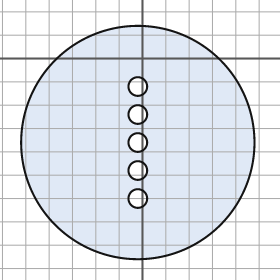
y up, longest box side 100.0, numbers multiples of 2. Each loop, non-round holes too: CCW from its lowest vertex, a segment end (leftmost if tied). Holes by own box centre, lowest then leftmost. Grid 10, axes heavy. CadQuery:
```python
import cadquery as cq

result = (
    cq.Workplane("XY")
    .moveTo(-2.0, -36.0)
    .circle(50.0)
    .moveTo(-2.0, -60.0)
    .circle(4.0)
    .moveTo(-2.0, -48.0)
    .circle(4.0)
    .moveTo(-2.0, -36.0)
    .circle(4.0)
    .moveTo(-2.0, -24.0)
    .circle(4.0)
    .moveTo(-2.0, -12.0)
    .circle(4.0)
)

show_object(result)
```